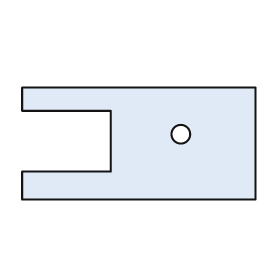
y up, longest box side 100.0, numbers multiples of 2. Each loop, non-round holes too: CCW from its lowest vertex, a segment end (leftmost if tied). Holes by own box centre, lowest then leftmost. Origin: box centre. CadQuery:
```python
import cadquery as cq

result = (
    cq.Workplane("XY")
    .moveTo(-50.0, -24.0)
    .lineTo(50.0, -24.0)
    .lineTo(50.0, 24.0)
    .lineTo(-50.0, 24.0)
    .lineTo(-50.0, 14.0)
    .lineTo(-12.0, 14.0)
    .lineTo(-12.0, -12.0)
    .lineTo(-50.0, -12.0)
    .close()
    .moveTo(18.0, 4.0)
    .circle(4.0)
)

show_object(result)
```